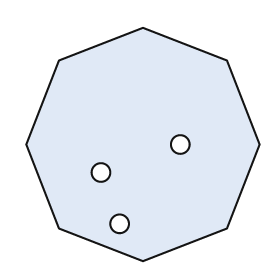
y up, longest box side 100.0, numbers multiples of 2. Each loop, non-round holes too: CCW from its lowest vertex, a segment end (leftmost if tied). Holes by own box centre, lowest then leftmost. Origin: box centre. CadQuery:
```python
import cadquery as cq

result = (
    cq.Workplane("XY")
    .moveTo(0.0, -50.0)
    .lineTo(36.0, -36.0)
    .lineTo(50.0, 0.0)
    .lineTo(36.0, 36.0)
    .lineTo(0.0, 50.0)
    .lineTo(-36.0, 36.0)
    .lineTo(-50.0, 0.0)
    .lineTo(-36.0, -36.0)
    .close()
    .moveTo(-10.0, -34.0)
    .circle(4.0)
    .moveTo(-18.0, -12.0)
    .circle(4.0)
    .moveTo(16.0, 0.0)
    .circle(4.0)
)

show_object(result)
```